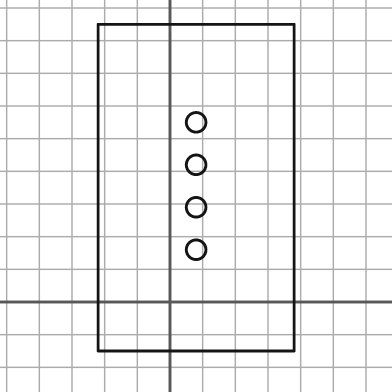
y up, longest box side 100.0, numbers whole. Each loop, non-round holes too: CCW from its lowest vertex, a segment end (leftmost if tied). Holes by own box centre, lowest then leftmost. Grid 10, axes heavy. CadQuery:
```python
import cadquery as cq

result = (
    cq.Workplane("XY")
    .moveTo(-22.0, -15.0)
    .lineTo(38.0, -15.0)
    .lineTo(38.0, 85.0)
    .lineTo(-22.0, 85.0)
    .close()
    .moveTo(8.0, 16.0)
    .circle(3.0)
    .moveTo(8.0, 29.0)
    .circle(3.0)
    .moveTo(8.0, 42.0)
    .circle(3.0)
    .moveTo(8.0, 55.0)
    .circle(3.0)
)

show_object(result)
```